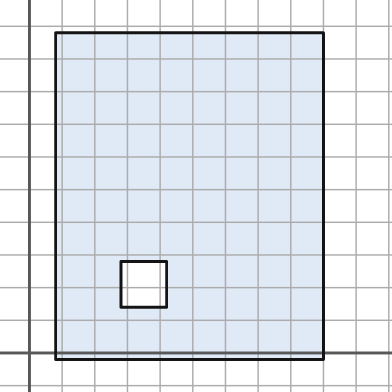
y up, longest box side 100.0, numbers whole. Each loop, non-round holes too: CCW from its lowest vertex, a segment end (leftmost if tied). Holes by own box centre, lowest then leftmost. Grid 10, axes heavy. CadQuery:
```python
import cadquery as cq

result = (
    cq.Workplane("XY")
    .moveTo(8.0, -2.0)
    .lineTo(90.0, -2.0)
    .lineTo(90.0, 98.0)
    .lineTo(8.0, 98.0)
    .close()
    .moveTo(28.0, 14.0)
    .lineTo(42.0, 14.0)
    .lineTo(42.0, 28.0)
    .lineTo(28.0, 28.0)
    .close()
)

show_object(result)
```